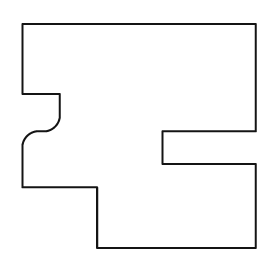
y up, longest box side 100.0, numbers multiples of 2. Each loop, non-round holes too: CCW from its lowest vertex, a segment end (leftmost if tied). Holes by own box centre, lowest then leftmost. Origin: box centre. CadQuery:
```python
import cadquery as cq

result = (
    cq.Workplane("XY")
    .moveTo(-18.0, -48.0)
    .lineTo(50.0, -48.0)
    .lineTo(50.0, -12.0)
    .lineTo(10.0, -12.0)
    .lineTo(10.0, 2.0)
    .lineTo(50.0, 2.0)
    .lineTo(50.0, 48.0)
    .lineTo(-50.0, 48.0)
    .lineTo(-50.0, 18.0)
    .lineTo(-34.0, 18.0)
    .lineTo(-34.0, 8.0)
    .threePointArc((-36.0, 4.0), (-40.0, 2.0))
    .lineTo(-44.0, 2.0)
    .threePointArc((-48.0, 0.0), (-50.0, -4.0))
    .lineTo(-50.0, -22.0)
    .lineTo(-18.0, -22.0)
    .close()
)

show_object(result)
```